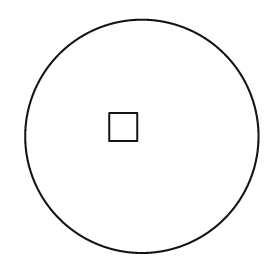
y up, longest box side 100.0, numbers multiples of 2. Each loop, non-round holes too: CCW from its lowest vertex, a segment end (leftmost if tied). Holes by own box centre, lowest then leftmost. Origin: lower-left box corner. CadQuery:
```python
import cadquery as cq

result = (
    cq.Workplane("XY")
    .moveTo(50.0, 50.0)
    .circle(50.0)
    .moveTo(36.0, 48.0)
    .lineTo(48.0, 48.0)
    .lineTo(48.0, 60.0)
    .lineTo(36.0, 60.0)
    .close()
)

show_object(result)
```